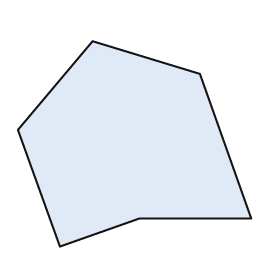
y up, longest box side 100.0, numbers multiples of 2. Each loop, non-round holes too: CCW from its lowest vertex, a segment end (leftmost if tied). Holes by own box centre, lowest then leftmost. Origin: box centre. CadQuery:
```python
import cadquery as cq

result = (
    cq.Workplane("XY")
    .moveTo(-32.0, -44.0)
    .lineTo(2.0, -32.0)
    .lineTo(50.0, -32.0)
    .lineTo(28.0, 30.0)
    .lineTo(-18.0, 44.0)
    .lineTo(-50.0, 6.0)
    .close()
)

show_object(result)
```